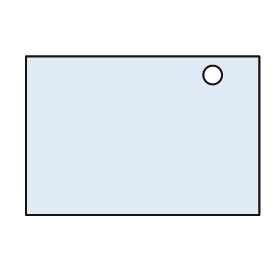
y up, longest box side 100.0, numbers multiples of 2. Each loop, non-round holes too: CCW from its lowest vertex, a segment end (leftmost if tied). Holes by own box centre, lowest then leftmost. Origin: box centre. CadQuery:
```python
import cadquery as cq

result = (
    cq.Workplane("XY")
    .moveTo(-50.0, -34.0)
    .lineTo(50.0, -34.0)
    .lineTo(50.0, 34.0)
    .lineTo(-50.0, 34.0)
    .close()
    .moveTo(30.0, 26.0)
    .circle(4.0)
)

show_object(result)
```